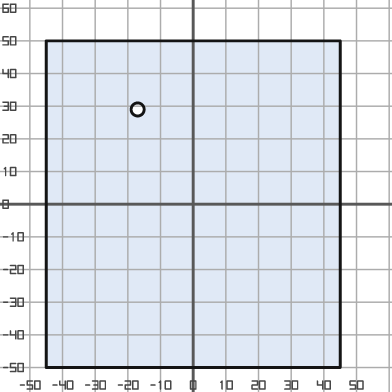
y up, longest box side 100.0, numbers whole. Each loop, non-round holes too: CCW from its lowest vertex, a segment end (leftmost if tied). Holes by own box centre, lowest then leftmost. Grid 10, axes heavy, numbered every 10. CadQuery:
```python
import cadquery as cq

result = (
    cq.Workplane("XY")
    .moveTo(-45.0, -50.0)
    .lineTo(45.0, -50.0)
    .lineTo(45.0, 50.0)
    .lineTo(-45.0, 50.0)
    .close()
    .moveTo(-17.0, 29.0)
    .circle(2.0)
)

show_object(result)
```